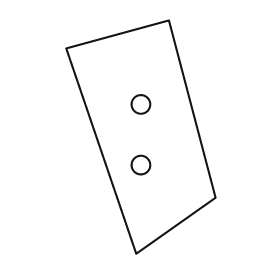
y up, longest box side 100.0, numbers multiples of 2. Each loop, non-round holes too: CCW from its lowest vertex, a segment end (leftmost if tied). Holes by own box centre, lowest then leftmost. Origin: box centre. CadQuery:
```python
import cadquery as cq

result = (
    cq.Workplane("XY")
    .moveTo(-2.0, -50.0)
    .lineTo(32.0, -26.0)
    .lineTo(12.0, 50.0)
    .lineTo(-32.0, 38.0)
    .close()
    .moveTo(0.0, -12.0)
    .circle(4.0)
    .moveTo(0.0, 14.0)
    .circle(4.0)
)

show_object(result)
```